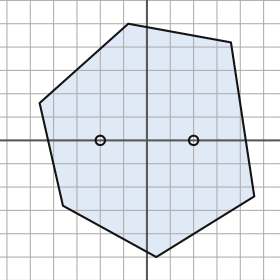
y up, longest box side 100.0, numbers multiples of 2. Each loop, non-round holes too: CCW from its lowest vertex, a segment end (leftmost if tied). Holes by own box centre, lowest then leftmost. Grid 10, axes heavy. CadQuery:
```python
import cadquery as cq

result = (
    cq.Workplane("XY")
    .moveTo(4.0, -50.0)
    .lineTo(46.0, -24.0)
    .lineTo(36.0, 42.0)
    .lineTo(-8.0, 50.0)
    .lineTo(-46.0, 16.0)
    .lineTo(-36.0, -28.0)
    .close()
    .moveTo(-20.0, 0.0)
    .circle(2.0)
    .moveTo(20.0, 0.0)
    .circle(2.0)
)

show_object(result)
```